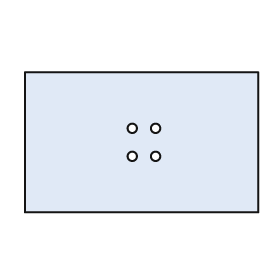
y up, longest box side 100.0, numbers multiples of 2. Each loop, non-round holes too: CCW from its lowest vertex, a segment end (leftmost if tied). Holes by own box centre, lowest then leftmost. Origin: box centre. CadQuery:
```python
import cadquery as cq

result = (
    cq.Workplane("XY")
    .moveTo(-50.0, -30.0)
    .lineTo(50.0, -30.0)
    .lineTo(50.0, 30.0)
    .lineTo(-50.0, 30.0)
    .close()
    .moveTo(-4.0, -6.0)
    .circle(2.0)
    .moveTo(6.0, -6.0)
    .circle(2.0)
    .moveTo(-4.0, 6.0)
    .circle(2.0)
    .moveTo(6.0, 6.0)
    .circle(2.0)
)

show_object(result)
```